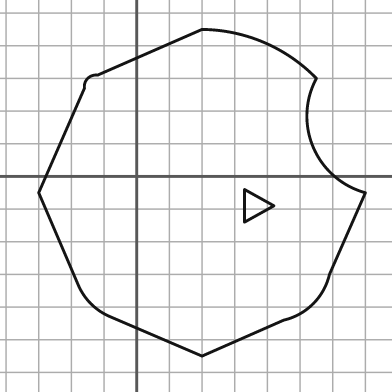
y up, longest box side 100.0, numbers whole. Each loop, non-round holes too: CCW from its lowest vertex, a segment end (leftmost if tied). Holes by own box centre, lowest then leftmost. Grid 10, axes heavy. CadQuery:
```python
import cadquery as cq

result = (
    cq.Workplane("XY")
    .moveTo(20.0, -55.0)
    .lineTo(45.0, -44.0)
    .threePointArc((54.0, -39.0), (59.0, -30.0))
    .lineTo(70.0, -5.0)
    .threePointArc((54.0, 9.0), (55.0, 30.0))
    .threePointArc((39.0, 41.0), (20.0, 45.0))
    .lineTo(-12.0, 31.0)
    .threePointArc((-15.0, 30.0), (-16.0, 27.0))
    .lineTo(-30.0, -5.0)
    .lineTo(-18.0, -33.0)
    .threePointArc((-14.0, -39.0), (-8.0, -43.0))
    .close()
    .moveTo(33.0, -14.0)
    .lineTo(42.0, -9.0)
    .lineTo(33.0, -4.0)
    .close()
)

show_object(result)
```